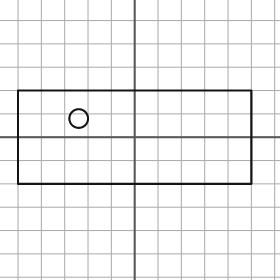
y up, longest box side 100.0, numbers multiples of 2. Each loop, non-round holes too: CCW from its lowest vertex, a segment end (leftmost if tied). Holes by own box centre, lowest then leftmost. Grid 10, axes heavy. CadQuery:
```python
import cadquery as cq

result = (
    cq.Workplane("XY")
    .moveTo(-50.0, -20.0)
    .lineTo(50.0, -20.0)
    .lineTo(50.0, 20.0)
    .lineTo(-50.0, 20.0)
    .close()
    .moveTo(-24.0, 8.0)
    .circle(4.0)
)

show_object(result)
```